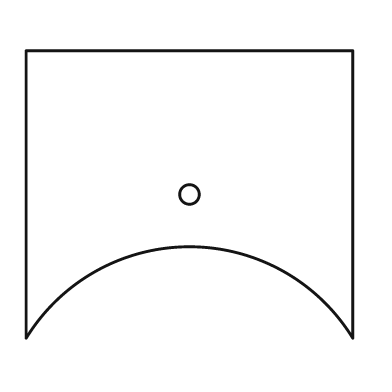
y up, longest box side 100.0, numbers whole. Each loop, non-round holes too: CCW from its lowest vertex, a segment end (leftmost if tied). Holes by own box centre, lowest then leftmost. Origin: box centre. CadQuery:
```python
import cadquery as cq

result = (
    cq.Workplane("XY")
    .moveTo(-50.0, -44.0)
    .threePointArc((0.0, -16.0), (50.0, -44.0))
    .lineTo(50.0, 44.0)
    .lineTo(-50.0, 44.0)
    .close()
    .moveTo(0.0, 0.0)
    .circle(3.0)
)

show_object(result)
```